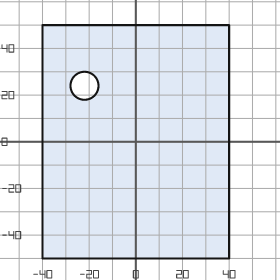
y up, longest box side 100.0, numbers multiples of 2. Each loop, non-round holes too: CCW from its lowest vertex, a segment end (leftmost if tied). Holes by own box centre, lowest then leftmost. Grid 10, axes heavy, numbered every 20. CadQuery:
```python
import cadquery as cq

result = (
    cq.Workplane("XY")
    .moveTo(-40.0, -50.0)
    .lineTo(40.0, -50.0)
    .lineTo(40.0, 50.0)
    .lineTo(-40.0, 50.0)
    .close()
    .moveTo(-22.0, 24.0)
    .circle(6.0)
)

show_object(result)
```